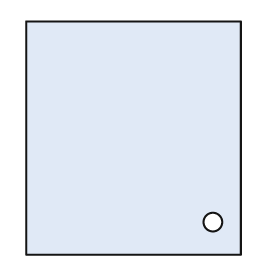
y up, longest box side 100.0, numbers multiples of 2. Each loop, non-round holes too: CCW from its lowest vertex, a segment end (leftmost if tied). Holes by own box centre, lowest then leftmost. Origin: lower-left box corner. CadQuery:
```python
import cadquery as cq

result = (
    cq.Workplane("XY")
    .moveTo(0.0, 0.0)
    .lineTo(92.0, 0.0)
    .lineTo(92.0, 100.0)
    .lineTo(0.0, 100.0)
    .close()
    .moveTo(80.0, 14.0)
    .circle(4.0)
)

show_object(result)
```